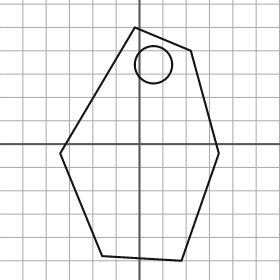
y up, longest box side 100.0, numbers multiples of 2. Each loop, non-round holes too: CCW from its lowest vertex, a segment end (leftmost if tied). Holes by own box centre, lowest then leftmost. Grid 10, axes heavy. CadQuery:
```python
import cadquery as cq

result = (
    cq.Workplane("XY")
    .moveTo(18.0, -50.0)
    .lineTo(34.0, -4.0)
    .lineTo(22.0, 40.0)
    .lineTo(-2.0, 50.0)
    .lineTo(-34.0, -4.0)
    .lineTo(-16.0, -48.0)
    .close()
    .moveTo(6.0, 34.0)
    .circle(8.0)
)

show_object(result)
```